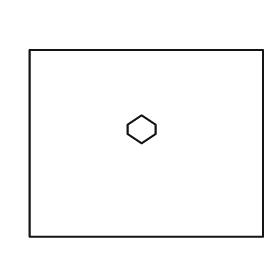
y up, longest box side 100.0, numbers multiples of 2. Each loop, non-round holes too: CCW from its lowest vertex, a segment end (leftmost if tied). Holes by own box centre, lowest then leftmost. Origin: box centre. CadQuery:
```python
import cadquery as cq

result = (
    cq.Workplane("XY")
    .moveTo(-50.0, -40.0)
    .lineTo(50.0, -40.0)
    .lineTo(50.0, 40.0)
    .lineTo(-50.0, 40.0)
    .close()
    .moveTo(-2.0, 0.0)
    .lineTo(4.0, 4.0)
    .lineTo(4.0, 8.0)
    .lineTo(-2.0, 12.0)
    .lineTo(-8.0, 8.0)
    .lineTo(-8.0, 4.0)
    .close()
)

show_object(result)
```